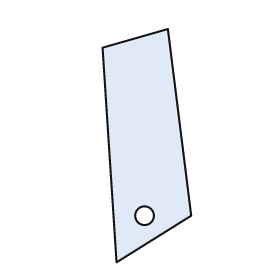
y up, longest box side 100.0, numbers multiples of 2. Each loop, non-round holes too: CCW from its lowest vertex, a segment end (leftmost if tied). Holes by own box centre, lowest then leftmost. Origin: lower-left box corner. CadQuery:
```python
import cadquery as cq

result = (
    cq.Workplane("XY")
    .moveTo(6.0, 0.0)
    .lineTo(38.0, 20.0)
    .lineTo(28.0, 100.0)
    .lineTo(0.0, 92.0)
    .close()
    .moveTo(18.0, 20.0)
    .circle(4.0)
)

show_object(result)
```